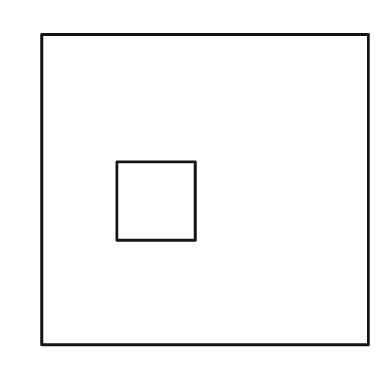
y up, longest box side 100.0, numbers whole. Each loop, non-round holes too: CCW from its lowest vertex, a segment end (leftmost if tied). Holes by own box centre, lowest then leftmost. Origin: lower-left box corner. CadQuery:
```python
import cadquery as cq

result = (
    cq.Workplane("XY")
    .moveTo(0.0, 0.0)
    .lineTo(100.0, 0.0)
    .lineTo(100.0, 95.0)
    .lineTo(0.0, 95.0)
    .close()
    .moveTo(23.0, 32.0)
    .lineTo(47.0, 32.0)
    .lineTo(47.0, 56.0)
    .lineTo(23.0, 56.0)
    .close()
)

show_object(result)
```